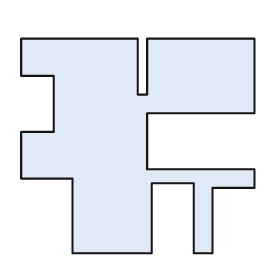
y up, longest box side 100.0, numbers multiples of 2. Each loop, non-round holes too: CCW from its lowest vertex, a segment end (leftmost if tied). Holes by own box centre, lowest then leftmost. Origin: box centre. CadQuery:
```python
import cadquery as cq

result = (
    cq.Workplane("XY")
    .moveTo(-28.0, -46.0)
    .lineTo(6.0, -46.0)
    .lineTo(6.0, -16.0)
    .lineTo(24.0, -16.0)
    .lineTo(24.0, -46.0)
    .lineTo(32.0, -46.0)
    .lineTo(32.0, -18.0)
    .lineTo(50.0, -18.0)
    .lineTo(50.0, -10.0)
    .lineTo(4.0, -10.0)
    .lineTo(4.0, 14.0)
    .lineTo(50.0, 14.0)
    .lineTo(50.0, 46.0)
    .lineTo(4.0, 46.0)
    .lineTo(4.0, 22.0)
    .lineTo(0.0, 22.0)
    .lineTo(0.0, 46.0)
    .lineTo(-50.0, 46.0)
    .lineTo(-50.0, 30.0)
    .lineTo(-36.0, 30.0)
    .lineTo(-36.0, 6.0)
    .lineTo(-50.0, 6.0)
    .lineTo(-50.0, -14.0)
    .lineTo(-28.0, -14.0)
    .close()
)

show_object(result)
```